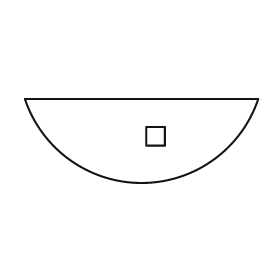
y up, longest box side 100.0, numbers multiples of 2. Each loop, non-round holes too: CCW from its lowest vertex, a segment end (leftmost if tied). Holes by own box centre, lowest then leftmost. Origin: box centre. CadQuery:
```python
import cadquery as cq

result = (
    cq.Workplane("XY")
    .moveTo(-50.0, 18.0)
    .threePointArc((0.0, -18.0), (50.0, 18.0))
    .close()
    .moveTo(2.0, -2.0)
    .lineTo(10.0, -2.0)
    .lineTo(10.0, 6.0)
    .lineTo(2.0, 6.0)
    .close()
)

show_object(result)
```